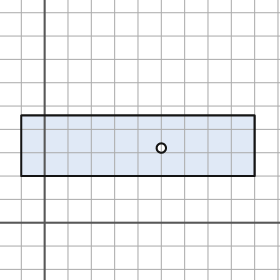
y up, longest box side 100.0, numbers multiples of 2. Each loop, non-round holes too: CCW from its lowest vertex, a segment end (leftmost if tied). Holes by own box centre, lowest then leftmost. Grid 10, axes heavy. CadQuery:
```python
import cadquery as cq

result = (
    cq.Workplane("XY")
    .moveTo(-10.0, 20.0)
    .lineTo(90.0, 20.0)
    .lineTo(90.0, 46.0)
    .lineTo(-10.0, 46.0)
    .close()
    .moveTo(50.0, 32.0)
    .circle(2.0)
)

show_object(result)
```